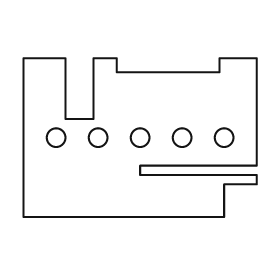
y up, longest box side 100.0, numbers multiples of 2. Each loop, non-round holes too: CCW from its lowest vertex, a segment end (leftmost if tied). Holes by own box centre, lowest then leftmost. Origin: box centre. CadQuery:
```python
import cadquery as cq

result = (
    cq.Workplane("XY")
    .moveTo(-50.0, -34.0)
    .lineTo(36.0, -34.0)
    .lineTo(36.0, -20.0)
    .lineTo(50.0, -20.0)
    .lineTo(50.0, -16.0)
    .lineTo(0.0, -16.0)
    .lineTo(0.0, -12.0)
    .lineTo(50.0, -12.0)
    .lineTo(50.0, 34.0)
    .lineTo(34.0, 34.0)
    .lineTo(34.0, 28.0)
    .lineTo(-10.0, 28.0)
    .lineTo(-10.0, 34.0)
    .lineTo(-20.0, 34.0)
    .lineTo(-20.0, 8.0)
    .lineTo(-32.0, 8.0)
    .lineTo(-32.0, 34.0)
    .lineTo(-50.0, 34.0)
    .close()
    .moveTo(-36.0, 0.0)
    .circle(4.0)
    .moveTo(-18.0, 0.0)
    .circle(4.0)
    .moveTo(0.0, 0.0)
    .circle(4.0)
    .moveTo(18.0, 0.0)
    .circle(4.0)
    .moveTo(36.0, 0.0)
    .circle(4.0)
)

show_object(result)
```